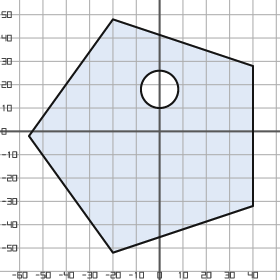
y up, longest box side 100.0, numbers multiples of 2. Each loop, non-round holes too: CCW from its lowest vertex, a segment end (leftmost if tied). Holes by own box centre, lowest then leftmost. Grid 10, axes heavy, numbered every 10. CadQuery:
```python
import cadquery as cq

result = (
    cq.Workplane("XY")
    .moveTo(-20.0, -52.0)
    .lineTo(40.0, -32.0)
    .lineTo(40.0, 28.0)
    .lineTo(-20.0, 48.0)
    .lineTo(-56.0, -2.0)
    .close()
    .moveTo(0.0, 18.0)
    .circle(8.0)
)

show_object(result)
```